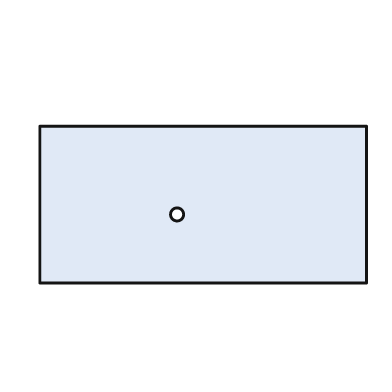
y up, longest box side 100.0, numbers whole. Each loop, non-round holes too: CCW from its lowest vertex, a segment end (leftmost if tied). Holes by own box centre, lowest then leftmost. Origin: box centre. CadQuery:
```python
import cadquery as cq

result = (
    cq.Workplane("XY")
    .moveTo(-50.0, -24.0)
    .lineTo(50.0, -24.0)
    .lineTo(50.0, 24.0)
    .lineTo(-50.0, 24.0)
    .close()
    .moveTo(-8.0, -3.0)
    .circle(2.0)
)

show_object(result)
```